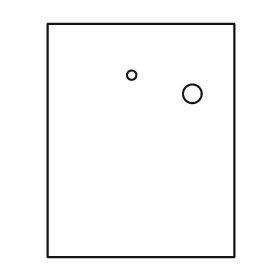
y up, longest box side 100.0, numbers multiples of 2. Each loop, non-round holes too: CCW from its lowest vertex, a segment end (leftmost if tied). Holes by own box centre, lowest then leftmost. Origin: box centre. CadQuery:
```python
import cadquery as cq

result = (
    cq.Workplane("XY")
    .moveTo(-40.0, -50.0)
    .lineTo(40.0, -50.0)
    .lineTo(40.0, 50.0)
    .lineTo(-40.0, 50.0)
    .close()
    .moveTo(22.0, 20.0)
    .circle(4.0)
    .moveTo(-4.0, 28.0)
    .circle(2.0)
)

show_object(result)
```